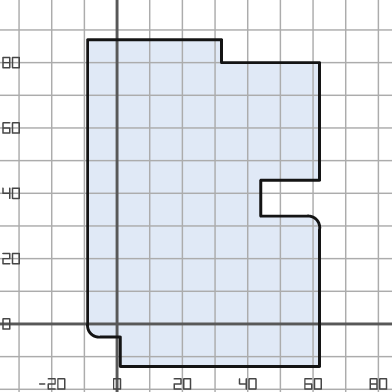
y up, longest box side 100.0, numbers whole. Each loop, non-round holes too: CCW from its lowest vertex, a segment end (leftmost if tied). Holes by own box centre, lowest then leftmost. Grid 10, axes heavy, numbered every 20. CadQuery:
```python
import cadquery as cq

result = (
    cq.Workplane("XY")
    .moveTo(1.0, -13.0)
    .lineTo(62.0, -13.0)
    .lineTo(62.0, 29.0)
    .threePointArc((61.0, 32.0), (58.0, 33.0))
    .lineTo(44.0, 33.0)
    .lineTo(44.0, 44.0)
    .lineTo(62.0, 44.0)
    .lineTo(62.0, 80.0)
    .lineTo(32.0, 80.0)
    .lineTo(32.0, 87.0)
    .lineTo(-9.0, 87.0)
    .lineTo(-9.0, 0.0)
    .threePointArc((-8.0, -3.0), (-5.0, -4.0))
    .lineTo(1.0, -4.0)
    .close()
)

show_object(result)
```